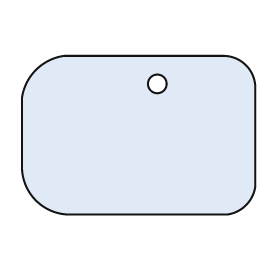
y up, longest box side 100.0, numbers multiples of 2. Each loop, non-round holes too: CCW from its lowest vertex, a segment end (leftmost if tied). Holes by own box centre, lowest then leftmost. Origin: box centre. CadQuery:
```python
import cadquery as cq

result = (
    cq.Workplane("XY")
    .moveTo(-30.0, -34.0)
    .lineTo(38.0, -34.0)
    .threePointArc((46.0, -30.0), (50.0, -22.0))
    .lineTo(50.0, 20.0)
    .threePointArc((46.0, 30.0), (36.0, 34.0))
    .lineTo(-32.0, 34.0)
    .threePointArc((-44.0, 28.0), (-50.0, 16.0))
    .lineTo(-50.0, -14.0)
    .threePointArc((-44.0, -28.0), (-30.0, -34.0))
    .close()
    .moveTo(8.0, 22.0)
    .circle(4.0)
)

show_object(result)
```